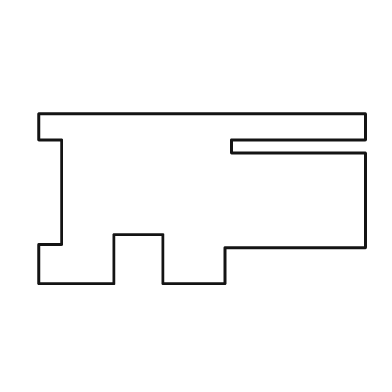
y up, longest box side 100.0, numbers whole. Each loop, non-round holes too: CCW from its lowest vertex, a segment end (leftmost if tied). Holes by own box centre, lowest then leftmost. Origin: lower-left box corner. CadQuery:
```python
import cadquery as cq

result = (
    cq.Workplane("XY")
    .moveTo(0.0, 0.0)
    .lineTo(23.0, 0.0)
    .lineTo(23.0, 15.0)
    .lineTo(38.0, 15.0)
    .lineTo(38.0, 0.0)
    .lineTo(57.0, 0.0)
    .lineTo(57.0, 11.0)
    .lineTo(100.0, 11.0)
    .lineTo(100.0, 40.0)
    .lineTo(59.0, 40.0)
    .lineTo(59.0, 44.0)
    .lineTo(100.0, 44.0)
    .lineTo(100.0, 52.0)
    .lineTo(0.0, 52.0)
    .lineTo(0.0, 44.0)
    .lineTo(7.0, 44.0)
    .lineTo(7.0, 12.0)
    .lineTo(0.0, 12.0)
    .close()
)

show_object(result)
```